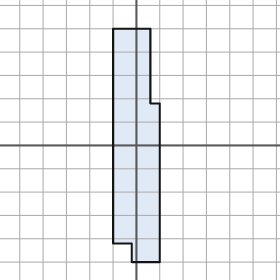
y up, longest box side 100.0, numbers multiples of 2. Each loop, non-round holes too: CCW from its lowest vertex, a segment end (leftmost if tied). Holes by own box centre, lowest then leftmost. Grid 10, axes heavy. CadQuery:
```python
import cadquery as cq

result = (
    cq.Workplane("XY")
    .moveTo(-2.0, -50.0)
    .lineTo(10.0, -50.0)
    .lineTo(10.0, 18.0)
    .lineTo(6.0, 18.0)
    .lineTo(6.0, 50.0)
    .lineTo(-10.0, 50.0)
    .lineTo(-10.0, -42.0)
    .lineTo(-2.0, -42.0)
    .close()
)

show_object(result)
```